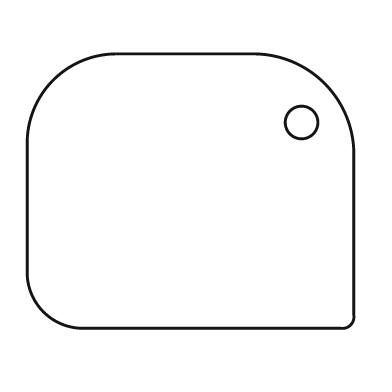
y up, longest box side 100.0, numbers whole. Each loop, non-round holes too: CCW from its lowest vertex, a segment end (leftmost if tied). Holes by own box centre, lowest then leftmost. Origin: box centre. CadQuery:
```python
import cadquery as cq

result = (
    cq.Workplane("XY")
    .moveTo(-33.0, -42.0)
    .lineTo(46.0, -42.0)
    .threePointArc((49.0, -41.0), (50.0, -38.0))
    .lineTo(50.0, 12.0)
    .threePointArc((41.0, 33.0), (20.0, 42.0))
    .lineTo(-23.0, 42.0)
    .threePointArc((-42.0, 34.0), (-50.0, 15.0))
    .lineTo(-50.0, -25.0)
    .threePointArc((-45.0, -37.0), (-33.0, -42.0))
    .close()
    .moveTo(34.0, 21.0)
    .circle(5.0)
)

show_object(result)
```